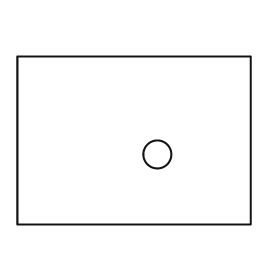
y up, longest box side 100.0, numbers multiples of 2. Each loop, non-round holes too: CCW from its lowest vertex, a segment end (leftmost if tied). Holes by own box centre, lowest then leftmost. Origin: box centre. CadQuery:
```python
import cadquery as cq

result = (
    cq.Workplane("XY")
    .moveTo(-50.0, -36.0)
    .lineTo(50.0, -36.0)
    .lineTo(50.0, 36.0)
    .lineTo(-50.0, 36.0)
    .close()
    .moveTo(10.0, -6.0)
    .circle(6.0)
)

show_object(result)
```